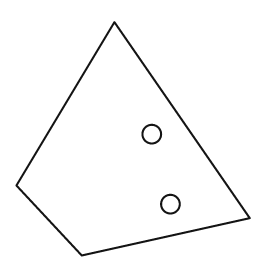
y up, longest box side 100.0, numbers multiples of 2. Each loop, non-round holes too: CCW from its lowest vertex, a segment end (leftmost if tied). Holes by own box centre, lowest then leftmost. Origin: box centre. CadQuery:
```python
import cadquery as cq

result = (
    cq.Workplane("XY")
    .moveTo(-22.0, -50.0)
    .lineTo(50.0, -34.0)
    .lineTo(-8.0, 50.0)
    .lineTo(-50.0, -20.0)
    .close()
    .moveTo(16.0, -28.0)
    .circle(4.0)
    .moveTo(8.0, 2.0)
    .circle(4.0)
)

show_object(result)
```